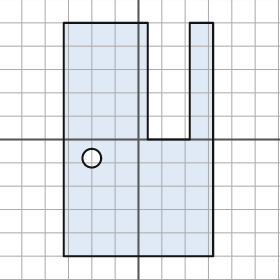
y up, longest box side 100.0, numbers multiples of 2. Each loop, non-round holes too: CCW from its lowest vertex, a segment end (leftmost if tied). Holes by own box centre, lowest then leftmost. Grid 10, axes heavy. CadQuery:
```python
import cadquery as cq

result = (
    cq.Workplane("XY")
    .moveTo(-32.0, -50.0)
    .lineTo(32.0, -50.0)
    .lineTo(32.0, 50.0)
    .lineTo(22.0, 50.0)
    .lineTo(22.0, 0.0)
    .lineTo(4.0, 0.0)
    .lineTo(4.0, 50.0)
    .lineTo(-32.0, 50.0)
    .close()
    .moveTo(-20.0, -8.0)
    .circle(4.0)
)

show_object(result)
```